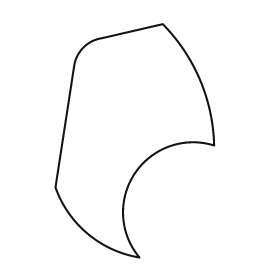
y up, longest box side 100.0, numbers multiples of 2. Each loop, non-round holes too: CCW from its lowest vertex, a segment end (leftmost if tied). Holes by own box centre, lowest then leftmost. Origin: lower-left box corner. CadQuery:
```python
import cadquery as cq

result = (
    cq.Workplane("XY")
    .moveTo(36.0, 0.0)
    .threePointArc((34.0, 36.0), (68.0, 48.0))
    .threePointArc((62.0, 76.0), (46.0, 100.0))
    .lineTo(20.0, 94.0)
    .threePointArc((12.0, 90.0), (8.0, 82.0))
    .lineTo(0.0, 30.0)
    .threePointArc((14.0, 10.0), (36.0, 0.0))
    .close()
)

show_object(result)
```